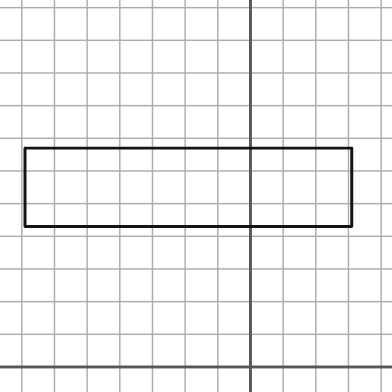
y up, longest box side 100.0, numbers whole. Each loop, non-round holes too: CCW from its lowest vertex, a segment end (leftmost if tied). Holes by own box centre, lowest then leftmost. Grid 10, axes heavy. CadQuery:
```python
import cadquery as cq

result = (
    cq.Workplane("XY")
    .moveTo(-69.0, 43.0)
    .lineTo(31.0, 43.0)
    .lineTo(31.0, 67.0)
    .lineTo(-69.0, 67.0)
    .close()
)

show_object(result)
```